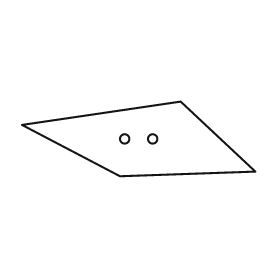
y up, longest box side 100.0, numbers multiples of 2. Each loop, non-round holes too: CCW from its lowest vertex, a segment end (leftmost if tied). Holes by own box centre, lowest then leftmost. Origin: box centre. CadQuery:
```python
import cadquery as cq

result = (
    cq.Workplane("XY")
    .moveTo(-8.0, -16.0)
    .lineTo(50.0, -14.0)
    .lineTo(18.0, 16.0)
    .lineTo(-50.0, 6.0)
    .close()
    .moveTo(-6.0, 0.0)
    .circle(2.0)
    .moveTo(6.0, 0.0)
    .circle(2.0)
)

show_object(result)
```